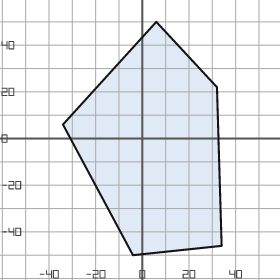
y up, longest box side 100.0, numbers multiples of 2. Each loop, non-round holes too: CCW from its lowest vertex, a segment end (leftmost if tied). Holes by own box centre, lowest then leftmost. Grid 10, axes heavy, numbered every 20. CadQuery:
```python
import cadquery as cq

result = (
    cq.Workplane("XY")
    .moveTo(-4.0, -50.0)
    .lineTo(34.0, -46.0)
    .lineTo(32.0, 22.0)
    .lineTo(6.0, 50.0)
    .lineTo(-34.0, 6.0)
    .close()
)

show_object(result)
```